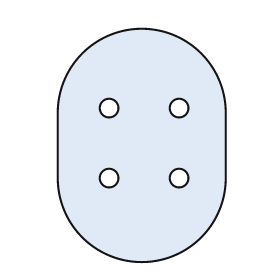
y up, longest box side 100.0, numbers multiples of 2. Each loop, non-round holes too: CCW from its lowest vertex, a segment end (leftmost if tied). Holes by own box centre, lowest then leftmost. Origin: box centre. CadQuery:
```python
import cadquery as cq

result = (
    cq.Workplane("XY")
    .moveTo(-36.0, -14.0)
    .threePointArc((0.0, -50.0), (36.0, -14.0))
    .lineTo(36.0, 14.0)
    .threePointArc((0.0, 50.0), (-36.0, 14.0))
    .close()
    .moveTo(-14.0, -14.0)
    .circle(4.0)
    .moveTo(16.0, -14.0)
    .circle(4.0)
    .moveTo(-14.0, 16.0)
    .circle(4.0)
    .moveTo(16.0, 16.0)
    .circle(4.0)
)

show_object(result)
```